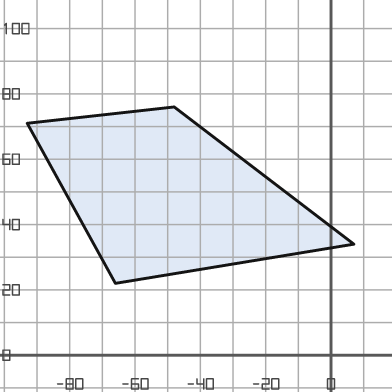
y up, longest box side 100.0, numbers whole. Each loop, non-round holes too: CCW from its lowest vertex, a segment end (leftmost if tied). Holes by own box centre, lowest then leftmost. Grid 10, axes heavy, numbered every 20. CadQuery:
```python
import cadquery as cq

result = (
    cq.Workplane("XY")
    .moveTo(-66.0, 22.0)
    .lineTo(7.0, 34.0)
    .lineTo(-48.0, 76.0)
    .lineTo(-93.0, 71.0)
    .close()
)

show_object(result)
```